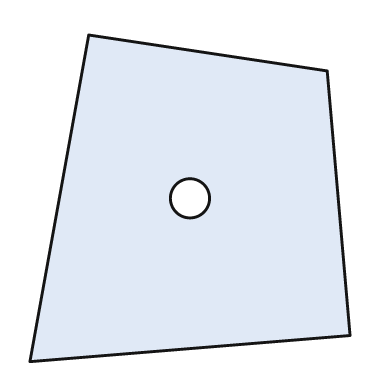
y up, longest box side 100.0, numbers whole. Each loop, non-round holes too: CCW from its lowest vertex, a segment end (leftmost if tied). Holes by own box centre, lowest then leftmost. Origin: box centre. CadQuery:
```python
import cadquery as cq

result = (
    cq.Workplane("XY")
    .moveTo(-49.0, -50.0)
    .lineTo(49.0, -42.0)
    .lineTo(42.0, 39.0)
    .lineTo(-31.0, 50.0)
    .close()
    .moveTo(0.0, 0.0)
    .circle(6.0)
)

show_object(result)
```